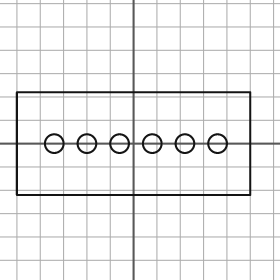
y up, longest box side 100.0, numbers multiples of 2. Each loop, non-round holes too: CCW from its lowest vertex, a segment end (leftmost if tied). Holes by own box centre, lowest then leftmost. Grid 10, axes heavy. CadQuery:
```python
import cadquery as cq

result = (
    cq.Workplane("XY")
    .moveTo(-50.0, -22.0)
    .lineTo(50.0, -22.0)
    .lineTo(50.0, 22.0)
    .lineTo(-50.0, 22.0)
    .close()
    .moveTo(-34.0, 0.0)
    .circle(4.0)
    .moveTo(-20.0, 0.0)
    .circle(4.0)
    .moveTo(-6.0, 0.0)
    .circle(4.0)
    .moveTo(8.0, 0.0)
    .circle(4.0)
    .moveTo(22.0, 0.0)
    .circle(4.0)
    .moveTo(36.0, 0.0)
    .circle(4.0)
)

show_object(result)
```